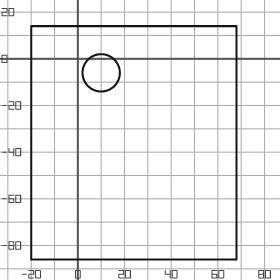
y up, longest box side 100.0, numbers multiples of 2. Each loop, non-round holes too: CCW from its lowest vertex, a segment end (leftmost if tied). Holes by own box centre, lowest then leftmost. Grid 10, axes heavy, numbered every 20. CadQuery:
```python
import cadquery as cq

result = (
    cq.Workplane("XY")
    .moveTo(-20.0, -86.0)
    .lineTo(68.0, -86.0)
    .lineTo(68.0, 14.0)
    .lineTo(-20.0, 14.0)
    .close()
    .moveTo(10.0, -6.0)
    .circle(8.0)
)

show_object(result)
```